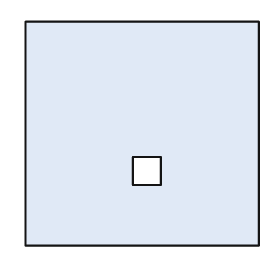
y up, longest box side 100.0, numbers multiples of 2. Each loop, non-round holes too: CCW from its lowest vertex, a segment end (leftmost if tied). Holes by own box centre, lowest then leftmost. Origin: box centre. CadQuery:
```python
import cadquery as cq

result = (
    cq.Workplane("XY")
    .moveTo(-50.0, -48.0)
    .lineTo(50.0, -48.0)
    .lineTo(50.0, 48.0)
    .lineTo(-50.0, 48.0)
    .close()
    .moveTo(-4.0, -22.0)
    .lineTo(8.0, -22.0)
    .lineTo(8.0, -10.0)
    .lineTo(-4.0, -10.0)
    .close()
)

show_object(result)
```